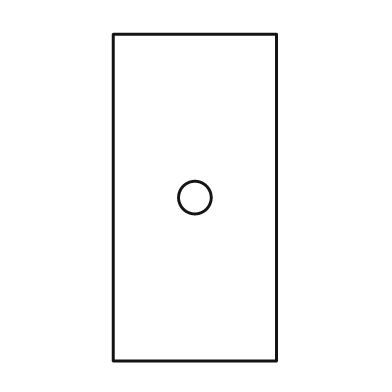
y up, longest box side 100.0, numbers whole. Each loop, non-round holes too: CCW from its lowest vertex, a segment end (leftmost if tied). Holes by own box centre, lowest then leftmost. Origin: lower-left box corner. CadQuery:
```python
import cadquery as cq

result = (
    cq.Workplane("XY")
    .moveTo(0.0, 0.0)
    .lineTo(50.0, 0.0)
    .lineTo(50.0, 100.0)
    .lineTo(0.0, 100.0)
    .close()
    .moveTo(25.0, 50.0)
    .circle(5.0)
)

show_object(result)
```